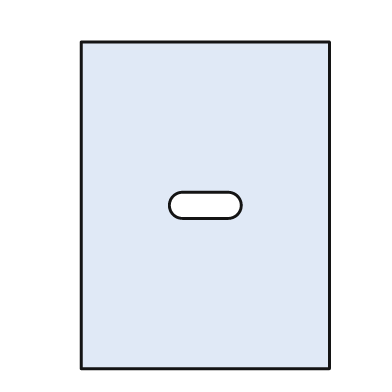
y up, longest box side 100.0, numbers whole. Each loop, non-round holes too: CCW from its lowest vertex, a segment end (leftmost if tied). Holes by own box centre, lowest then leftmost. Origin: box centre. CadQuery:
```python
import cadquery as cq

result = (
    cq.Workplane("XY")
    .moveTo(-38.0, -50.0)
    .lineTo(38.0, -50.0)
    .lineTo(38.0, 50.0)
    .lineTo(-38.0, 50.0)
    .close()
    .moveTo(-7.0, -4.0)
    .lineTo(7.0, -4.0)
    .threePointArc((11.0, 0.0), (7.0, 4.0))
    .lineTo(-7.0, 4.0)
    .threePointArc((-11.0, 0.0), (-7.0, -4.0))
    .close()
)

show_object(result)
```